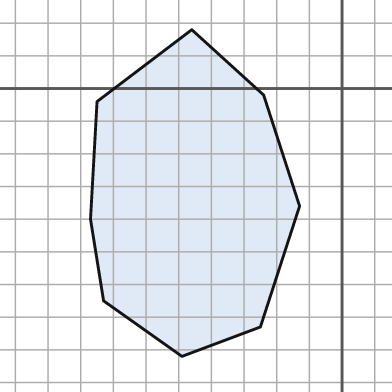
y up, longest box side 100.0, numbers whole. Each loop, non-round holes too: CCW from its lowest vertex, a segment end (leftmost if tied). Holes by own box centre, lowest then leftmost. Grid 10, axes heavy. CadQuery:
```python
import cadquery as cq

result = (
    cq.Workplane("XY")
    .moveTo(-49.0, -82.0)
    .lineTo(-25.0, -73.0)
    .lineTo(-13.0, -36.0)
    .lineTo(-24.0, -2.0)
    .lineTo(-46.0, 18.0)
    .lineTo(-75.0, -4.0)
    .lineTo(-77.0, -40.0)
    .lineTo(-73.0, -65.0)
    .close()
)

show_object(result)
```